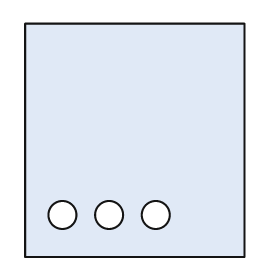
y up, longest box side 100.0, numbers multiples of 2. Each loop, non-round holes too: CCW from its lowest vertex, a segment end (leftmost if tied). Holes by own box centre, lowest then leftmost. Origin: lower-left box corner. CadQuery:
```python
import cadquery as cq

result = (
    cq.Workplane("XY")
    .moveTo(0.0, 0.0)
    .lineTo(94.0, 0.0)
    .lineTo(94.0, 100.0)
    .lineTo(0.0, 100.0)
    .close()
    .moveTo(16.0, 18.0)
    .circle(6.0)
    .moveTo(36.0, 18.0)
    .circle(6.0)
    .moveTo(56.0, 18.0)
    .circle(6.0)
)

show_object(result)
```